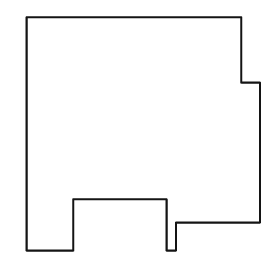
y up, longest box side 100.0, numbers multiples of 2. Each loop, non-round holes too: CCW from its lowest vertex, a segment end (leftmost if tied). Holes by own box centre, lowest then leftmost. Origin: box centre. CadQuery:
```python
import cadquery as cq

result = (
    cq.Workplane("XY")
    .moveTo(-50.0, -50.0)
    .lineTo(-30.0, -50.0)
    .lineTo(-30.0, -28.0)
    .lineTo(10.0, -28.0)
    .lineTo(10.0, -50.0)
    .lineTo(14.0, -50.0)
    .lineTo(14.0, -38.0)
    .lineTo(50.0, -38.0)
    .lineTo(50.0, 22.0)
    .lineTo(42.0, 22.0)
    .lineTo(42.0, 50.0)
    .lineTo(-50.0, 50.0)
    .close()
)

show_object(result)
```